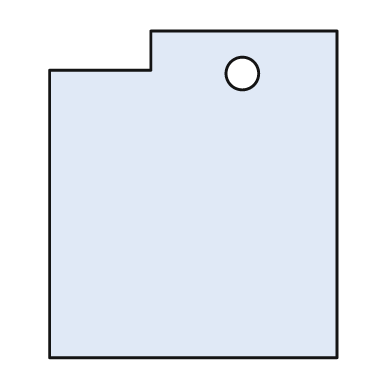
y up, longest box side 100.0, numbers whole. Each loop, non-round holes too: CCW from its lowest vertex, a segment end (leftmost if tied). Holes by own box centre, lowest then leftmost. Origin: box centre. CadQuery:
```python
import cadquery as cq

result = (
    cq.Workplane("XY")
    .moveTo(-44.0, -50.0)
    .lineTo(44.0, -50.0)
    .lineTo(44.0, 50.0)
    .lineTo(-13.0, 50.0)
    .lineTo(-13.0, 38.0)
    .lineTo(-44.0, 38.0)
    .close()
    .moveTo(15.0, 37.0)
    .circle(5.0)
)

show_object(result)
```